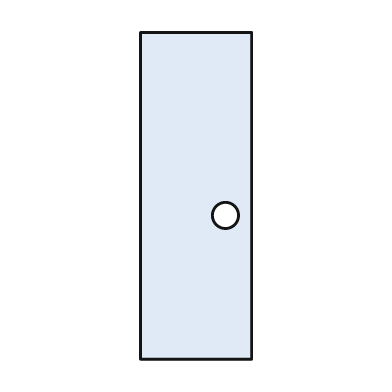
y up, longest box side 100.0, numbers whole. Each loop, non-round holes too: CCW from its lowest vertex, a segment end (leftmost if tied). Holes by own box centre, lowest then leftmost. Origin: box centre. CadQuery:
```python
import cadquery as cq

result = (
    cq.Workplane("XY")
    .moveTo(-17.0, -50.0)
    .lineTo(17.0, -50.0)
    .lineTo(17.0, 50.0)
    .lineTo(-17.0, 50.0)
    .close()
    .moveTo(9.0, -6.0)
    .circle(4.0)
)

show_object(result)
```